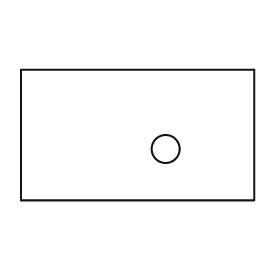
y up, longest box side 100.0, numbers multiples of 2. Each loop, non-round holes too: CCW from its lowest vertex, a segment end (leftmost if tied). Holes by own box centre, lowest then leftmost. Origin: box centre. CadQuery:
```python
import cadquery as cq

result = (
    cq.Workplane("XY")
    .moveTo(-50.0, -28.0)
    .lineTo(50.0, -28.0)
    .lineTo(50.0, 28.0)
    .lineTo(-50.0, 28.0)
    .close()
    .moveTo(12.0, -6.0)
    .circle(6.0)
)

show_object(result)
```